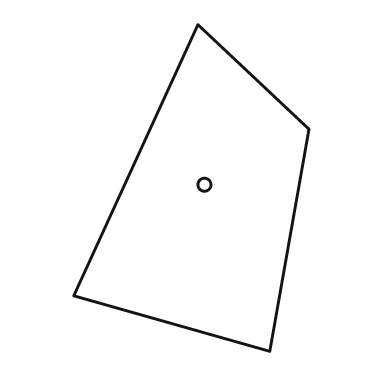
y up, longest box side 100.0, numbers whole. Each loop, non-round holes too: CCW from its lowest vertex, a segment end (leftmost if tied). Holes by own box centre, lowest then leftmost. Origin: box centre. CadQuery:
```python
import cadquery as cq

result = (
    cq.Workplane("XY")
    .moveTo(24.0, -50.0)
    .lineTo(36.0, 18.0)
    .lineTo(2.0, 50.0)
    .lineTo(-36.0, -33.0)
    .close()
    .moveTo(4.0, 1.0)
    .circle(2.0)
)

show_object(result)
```